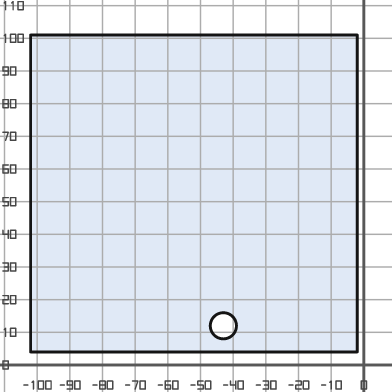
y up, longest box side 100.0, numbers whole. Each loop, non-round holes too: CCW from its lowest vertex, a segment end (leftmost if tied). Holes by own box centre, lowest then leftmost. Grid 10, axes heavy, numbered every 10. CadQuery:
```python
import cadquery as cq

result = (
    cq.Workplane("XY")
    .moveTo(-102.0, 4.0)
    .lineTo(-2.0, 4.0)
    .lineTo(-2.0, 101.0)
    .lineTo(-102.0, 101.0)
    .close()
    .moveTo(-43.0, 12.0)
    .circle(4.0)
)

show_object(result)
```